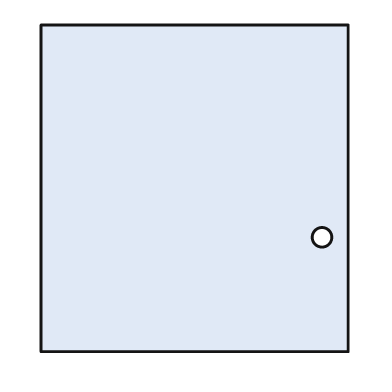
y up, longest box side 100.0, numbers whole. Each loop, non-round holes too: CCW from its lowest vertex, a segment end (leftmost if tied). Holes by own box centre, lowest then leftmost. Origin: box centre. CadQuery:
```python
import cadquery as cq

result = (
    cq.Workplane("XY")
    .moveTo(-47.0, -50.0)
    .lineTo(47.0, -50.0)
    .lineTo(47.0, 50.0)
    .lineTo(-47.0, 50.0)
    .close()
    .moveTo(39.0, -15.0)
    .circle(3.0)
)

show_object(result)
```